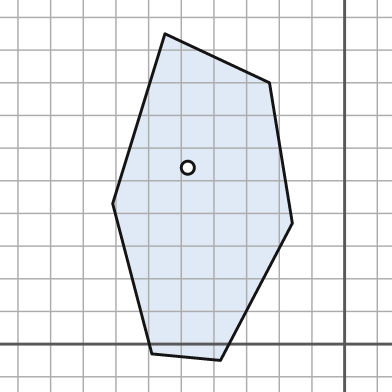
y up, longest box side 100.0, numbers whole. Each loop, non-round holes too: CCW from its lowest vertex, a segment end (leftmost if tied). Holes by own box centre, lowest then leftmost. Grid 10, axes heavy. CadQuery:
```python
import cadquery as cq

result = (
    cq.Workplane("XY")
    .moveTo(-38.0, -5.0)
    .lineTo(-16.0, 37.0)
    .lineTo(-23.0, 80.0)
    .lineTo(-55.0, 95.0)
    .lineTo(-71.0, 43.0)
    .lineTo(-59.0, -3.0)
    .close()
    .moveTo(-48.0, 54.0)
    .circle(2.0)
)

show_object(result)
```